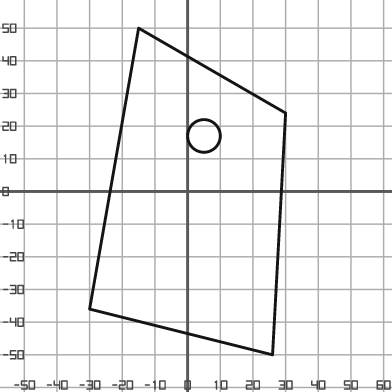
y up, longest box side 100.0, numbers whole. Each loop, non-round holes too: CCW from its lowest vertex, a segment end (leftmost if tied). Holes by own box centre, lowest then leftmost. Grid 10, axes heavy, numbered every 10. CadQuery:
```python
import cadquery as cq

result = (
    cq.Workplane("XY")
    .moveTo(26.0, -50.0)
    .lineTo(30.0, 24.0)
    .lineTo(-15.0, 50.0)
    .lineTo(-30.0, -36.0)
    .close()
    .moveTo(5.0, 17.0)
    .circle(5.0)
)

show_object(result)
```